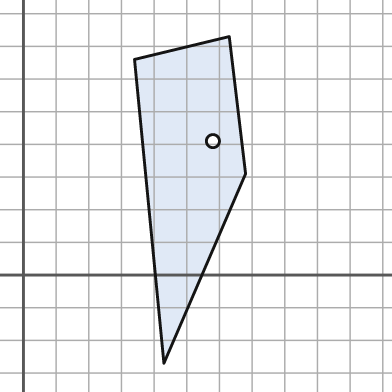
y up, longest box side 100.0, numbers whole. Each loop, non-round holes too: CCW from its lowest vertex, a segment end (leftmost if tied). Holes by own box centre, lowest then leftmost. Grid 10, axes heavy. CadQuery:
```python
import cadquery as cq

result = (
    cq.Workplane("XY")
    .moveTo(43.0, -27.0)
    .lineTo(68.0, 31.0)
    .lineTo(63.0, 73.0)
    .lineTo(34.0, 66.0)
    .close()
    .moveTo(58.0, 41.0)
    .circle(2.0)
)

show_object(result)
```